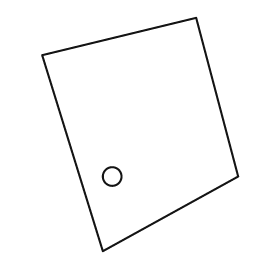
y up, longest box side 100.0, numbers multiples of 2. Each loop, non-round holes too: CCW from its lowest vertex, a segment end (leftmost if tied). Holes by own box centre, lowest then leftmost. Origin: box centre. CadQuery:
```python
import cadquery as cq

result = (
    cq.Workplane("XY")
    .moveTo(-16.0, -50.0)
    .lineTo(42.0, -18.0)
    .lineTo(24.0, 50.0)
    .lineTo(-42.0, 34.0)
    .close()
    .moveTo(-12.0, -18.0)
    .circle(4.0)
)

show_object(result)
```